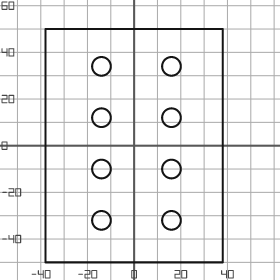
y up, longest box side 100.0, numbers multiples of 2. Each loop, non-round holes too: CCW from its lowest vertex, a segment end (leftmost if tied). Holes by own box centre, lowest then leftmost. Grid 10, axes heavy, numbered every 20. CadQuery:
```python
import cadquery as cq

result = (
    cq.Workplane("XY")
    .moveTo(-38.0, -50.0)
    .lineTo(38.0, -50.0)
    .lineTo(38.0, 50.0)
    .lineTo(-38.0, 50.0)
    .close()
    .moveTo(-14.0, -32.0)
    .circle(4.0)
    .moveTo(16.0, -32.0)
    .circle(4.0)
    .moveTo(-14.0, -10.0)
    .circle(4.0)
    .moveTo(16.0, -10.0)
    .circle(4.0)
    .moveTo(-14.0, 12.0)
    .circle(4.0)
    .moveTo(16.0, 12.0)
    .circle(4.0)
    .moveTo(-14.0, 34.0)
    .circle(4.0)
    .moveTo(16.0, 34.0)
    .circle(4.0)
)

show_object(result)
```